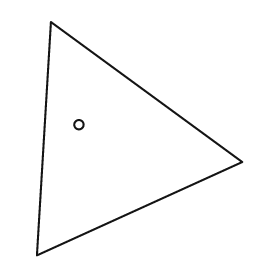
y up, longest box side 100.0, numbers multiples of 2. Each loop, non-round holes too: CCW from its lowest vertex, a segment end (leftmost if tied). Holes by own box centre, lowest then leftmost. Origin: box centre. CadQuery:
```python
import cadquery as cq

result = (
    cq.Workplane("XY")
    .moveTo(-44.0, -50.0)
    .lineTo(44.0, -10.0)
    .lineTo(-38.0, 50.0)
    .close()
    .moveTo(-26.0, 6.0)
    .circle(2.0)
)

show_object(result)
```